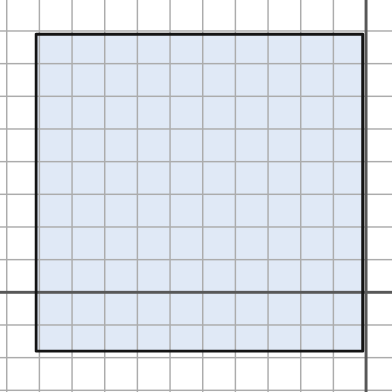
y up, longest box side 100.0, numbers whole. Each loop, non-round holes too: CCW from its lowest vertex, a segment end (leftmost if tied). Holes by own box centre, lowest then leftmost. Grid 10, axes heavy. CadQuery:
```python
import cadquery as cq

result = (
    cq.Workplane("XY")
    .moveTo(-101.0, -18.0)
    .lineTo(-1.0, -18.0)
    .lineTo(-1.0, 79.0)
    .lineTo(-101.0, 79.0)
    .close()
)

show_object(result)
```